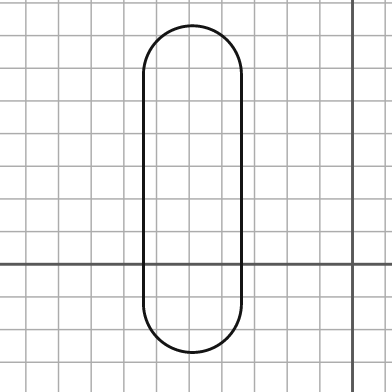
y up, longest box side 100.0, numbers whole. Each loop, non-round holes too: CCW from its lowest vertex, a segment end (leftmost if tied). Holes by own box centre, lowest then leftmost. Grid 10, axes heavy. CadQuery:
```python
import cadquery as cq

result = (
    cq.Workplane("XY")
    .moveTo(-64.0, -12.0)
    .threePointArc((-49.0, -27.0), (-34.0, -12.0))
    .lineTo(-34.0, 58.0)
    .threePointArc((-49.0, 73.0), (-64.0, 58.0))
    .close()
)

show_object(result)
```